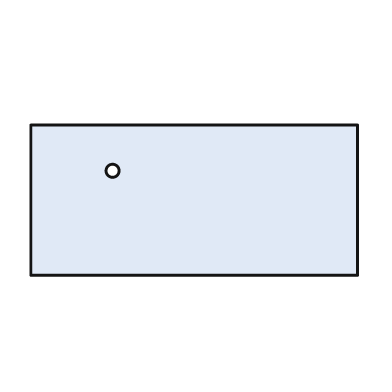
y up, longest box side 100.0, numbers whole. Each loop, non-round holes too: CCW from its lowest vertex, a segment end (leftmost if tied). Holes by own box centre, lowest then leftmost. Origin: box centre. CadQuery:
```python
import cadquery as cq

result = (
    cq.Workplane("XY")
    .moveTo(-50.0, -23.0)
    .lineTo(50.0, -23.0)
    .lineTo(50.0, 23.0)
    .lineTo(-50.0, 23.0)
    .close()
    .moveTo(-25.0, 9.0)
    .circle(2.0)
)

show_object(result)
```